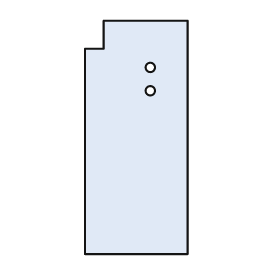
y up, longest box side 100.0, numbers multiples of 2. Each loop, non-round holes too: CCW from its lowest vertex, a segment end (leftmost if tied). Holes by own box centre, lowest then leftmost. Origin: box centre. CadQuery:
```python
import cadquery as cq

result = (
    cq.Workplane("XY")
    .moveTo(-22.0, -50.0)
    .lineTo(22.0, -50.0)
    .lineTo(22.0, 50.0)
    .lineTo(-14.0, 50.0)
    .lineTo(-14.0, 38.0)
    .lineTo(-22.0, 38.0)
    .close()
    .moveTo(6.0, 20.0)
    .circle(2.0)
    .moveTo(6.0, 30.0)
    .circle(2.0)
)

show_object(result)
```